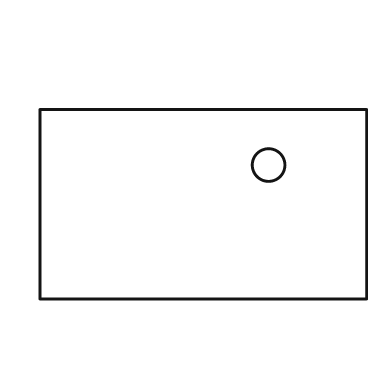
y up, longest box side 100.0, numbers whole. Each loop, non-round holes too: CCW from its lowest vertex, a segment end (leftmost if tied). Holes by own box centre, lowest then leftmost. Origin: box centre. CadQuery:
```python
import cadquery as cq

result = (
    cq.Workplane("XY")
    .moveTo(-50.0, -29.0)
    .lineTo(50.0, -29.0)
    .lineTo(50.0, 29.0)
    .lineTo(-50.0, 29.0)
    .close()
    .moveTo(20.0, 12.0)
    .circle(5.0)
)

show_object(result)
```